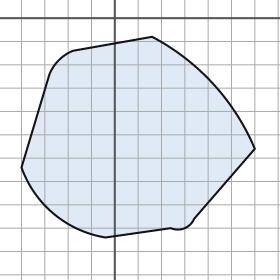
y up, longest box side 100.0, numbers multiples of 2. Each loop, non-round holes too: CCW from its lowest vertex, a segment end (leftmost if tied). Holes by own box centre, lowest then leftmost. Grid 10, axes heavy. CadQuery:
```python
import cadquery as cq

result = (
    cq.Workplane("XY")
    .moveTo(-4.0, -94.0)
    .lineTo(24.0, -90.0)
    .threePointArc((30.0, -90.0), (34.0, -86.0))
    .lineTo(60.0, -56.0)
    .threePointArc((42.0, -28.0), (16.0, -8.0))
    .lineTo(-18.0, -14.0)
    .threePointArc((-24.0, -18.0), (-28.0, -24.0))
    .lineTo(-40.0, -64.0)
    .threePointArc((-26.0, -84.0), (-4.0, -94.0))
    .close()
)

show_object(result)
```